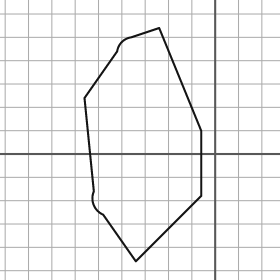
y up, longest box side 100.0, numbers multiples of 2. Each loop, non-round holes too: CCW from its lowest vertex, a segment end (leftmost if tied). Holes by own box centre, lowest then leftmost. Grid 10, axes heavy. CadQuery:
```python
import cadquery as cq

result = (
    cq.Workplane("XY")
    .moveTo(-34.0, -46.0)
    .lineTo(-6.0, -18.0)
    .lineTo(-6.0, 10.0)
    .lineTo(-24.0, 54.0)
    .lineTo(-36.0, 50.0)
    .threePointArc((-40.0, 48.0), (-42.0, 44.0))
    .lineTo(-56.0, 24.0)
    .lineTo(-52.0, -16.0)
    .threePointArc((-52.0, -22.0), (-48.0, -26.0))
    .close()
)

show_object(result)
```